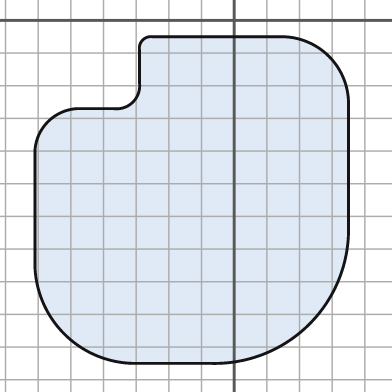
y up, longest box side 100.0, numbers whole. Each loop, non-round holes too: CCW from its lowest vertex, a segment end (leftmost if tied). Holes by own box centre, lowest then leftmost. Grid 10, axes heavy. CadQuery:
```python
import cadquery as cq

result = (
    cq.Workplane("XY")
    .moveTo(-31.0, -105.0)
    .lineTo(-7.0, -105.0)
    .threePointArc((23.0, -93.0), (35.0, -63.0))
    .lineTo(35.0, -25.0)
    .threePointArc((29.0, -11.0), (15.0, -5.0))
    .lineTo(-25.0, -5.0)
    .threePointArc((-28.0, -6.0), (-29.0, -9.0))
    .lineTo(-29.0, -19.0)
    .threePointArc((-31.0, -25.0), (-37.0, -27.0))
    .lineTo(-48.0, -27.0)
    .threePointArc((-57.0, -31.0), (-61.0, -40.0))
    .lineTo(-61.0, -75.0)
    .threePointArc((-52.0, -96.0), (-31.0, -105.0))
    .close()
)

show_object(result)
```